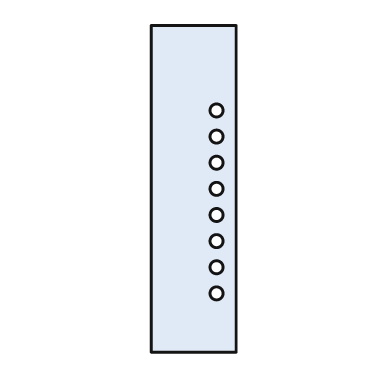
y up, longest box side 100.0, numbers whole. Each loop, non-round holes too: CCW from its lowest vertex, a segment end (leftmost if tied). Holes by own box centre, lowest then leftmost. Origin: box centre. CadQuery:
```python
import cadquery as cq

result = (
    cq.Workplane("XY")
    .moveTo(-13.0, -50.0)
    .lineTo(13.0, -50.0)
    .lineTo(13.0, 50.0)
    .lineTo(-13.0, 50.0)
    .close()
    .moveTo(7.0, -32.0)
    .circle(2.0)
    .moveTo(7.0, -24.0)
    .circle(2.0)
    .moveTo(7.0, -16.0)
    .circle(2.0)
    .moveTo(7.0, -8.0)
    .circle(2.0)
    .moveTo(7.0, 0.0)
    .circle(2.0)
    .moveTo(7.0, 8.0)
    .circle(2.0)
    .moveTo(7.0, 16.0)
    .circle(2.0)
    .moveTo(7.0, 24.0)
    .circle(2.0)
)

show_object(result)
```